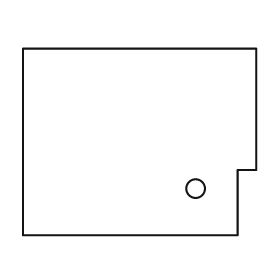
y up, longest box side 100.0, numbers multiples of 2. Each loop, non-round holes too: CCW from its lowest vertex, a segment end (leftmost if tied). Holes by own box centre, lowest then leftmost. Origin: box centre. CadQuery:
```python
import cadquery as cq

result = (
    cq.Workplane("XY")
    .moveTo(-50.0, -40.0)
    .lineTo(42.0, -40.0)
    .lineTo(42.0, -12.0)
    .lineTo(50.0, -12.0)
    .lineTo(50.0, 40.0)
    .lineTo(-50.0, 40.0)
    .close()
    .moveTo(24.0, -20.0)
    .circle(4.0)
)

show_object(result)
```